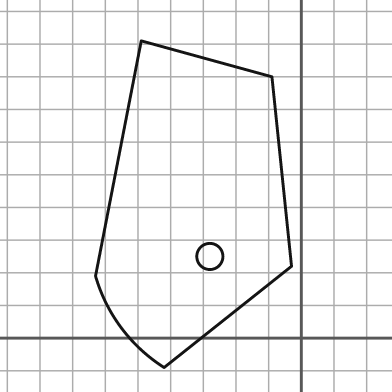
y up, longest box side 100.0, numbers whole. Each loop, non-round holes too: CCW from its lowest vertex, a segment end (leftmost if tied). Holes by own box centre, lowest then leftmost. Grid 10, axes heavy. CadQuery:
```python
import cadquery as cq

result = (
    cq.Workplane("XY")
    .moveTo(-42.0, -9.0)
    .lineTo(-3.0, 22.0)
    .lineTo(-9.0, 80.0)
    .lineTo(-49.0, 91.0)
    .lineTo(-63.0, 19.0)
    .threePointArc((-55.0, 3.0), (-42.0, -9.0))
    .close()
    .moveTo(-28.0, 25.0)
    .circle(4.0)
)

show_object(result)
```